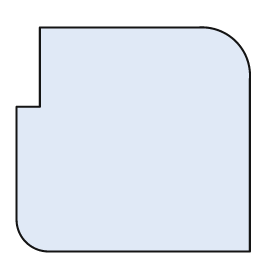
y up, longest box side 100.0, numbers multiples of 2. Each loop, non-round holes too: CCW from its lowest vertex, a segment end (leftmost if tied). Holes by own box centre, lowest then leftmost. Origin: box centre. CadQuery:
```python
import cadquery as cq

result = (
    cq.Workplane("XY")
    .moveTo(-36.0, -48.0)
    .lineTo(50.0, -48.0)
    .lineTo(50.0, 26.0)
    .threePointArc((44.0, 42.0), (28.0, 48.0))
    .lineTo(-40.0, 48.0)
    .lineTo(-40.0, 14.0)
    .lineTo(-50.0, 14.0)
    .lineTo(-50.0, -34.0)
    .threePointArc((-46.0, -44.0), (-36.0, -48.0))
    .close()
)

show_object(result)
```